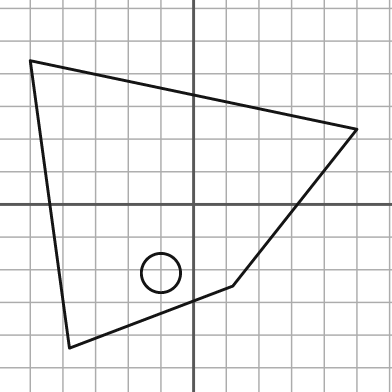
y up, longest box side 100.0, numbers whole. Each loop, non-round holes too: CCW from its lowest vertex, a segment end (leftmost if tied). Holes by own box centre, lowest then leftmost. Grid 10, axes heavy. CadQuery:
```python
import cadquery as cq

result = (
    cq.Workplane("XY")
    .moveTo(-38.0, -44.0)
    .lineTo(12.0, -25.0)
    .lineTo(50.0, 23.0)
    .lineTo(-50.0, 44.0)
    .close()
    .moveTo(-10.0, -21.0)
    .circle(6.0)
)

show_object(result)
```